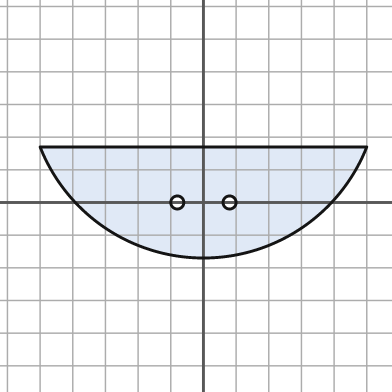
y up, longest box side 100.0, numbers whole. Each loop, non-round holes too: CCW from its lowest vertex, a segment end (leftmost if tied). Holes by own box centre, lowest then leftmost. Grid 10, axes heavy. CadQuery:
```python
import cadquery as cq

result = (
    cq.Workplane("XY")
    .moveTo(-50.0, 17.0)
    .threePointArc((0.0, -17.0), (50.0, 17.0))
    .close()
    .moveTo(-8.0, 0.0)
    .circle(2.0)
    .moveTo(8.0, 0.0)
    .circle(2.0)
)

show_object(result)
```